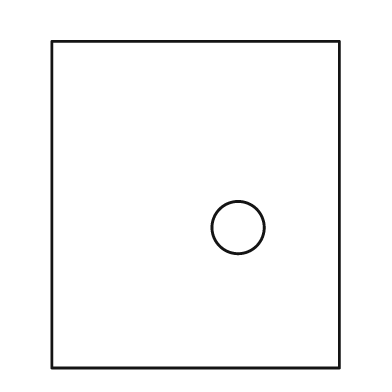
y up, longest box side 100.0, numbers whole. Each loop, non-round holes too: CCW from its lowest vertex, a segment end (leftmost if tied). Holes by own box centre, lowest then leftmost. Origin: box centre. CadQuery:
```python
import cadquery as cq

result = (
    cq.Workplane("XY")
    .moveTo(-44.0, -50.0)
    .lineTo(44.0, -50.0)
    .lineTo(44.0, 50.0)
    .lineTo(-44.0, 50.0)
    .close()
    .moveTo(13.0, -7.0)
    .circle(8.0)
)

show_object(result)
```